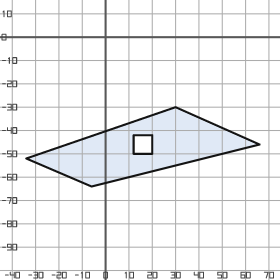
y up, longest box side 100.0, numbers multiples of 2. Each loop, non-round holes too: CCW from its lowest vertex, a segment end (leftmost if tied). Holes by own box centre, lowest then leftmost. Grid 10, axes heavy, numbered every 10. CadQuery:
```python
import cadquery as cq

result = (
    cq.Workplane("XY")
    .moveTo(-6.0, -64.0)
    .lineTo(66.0, -46.0)
    .lineTo(30.0, -30.0)
    .lineTo(-34.0, -52.0)
    .close()
    .moveTo(12.0, -50.0)
    .lineTo(20.0, -50.0)
    .lineTo(20.0, -42.0)
    .lineTo(12.0, -42.0)
    .close()
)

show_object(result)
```